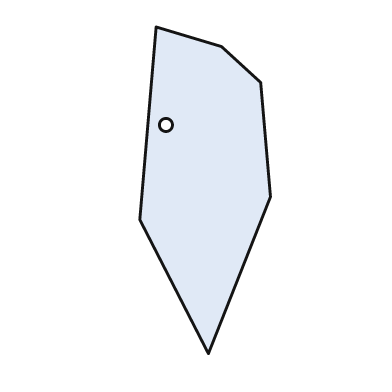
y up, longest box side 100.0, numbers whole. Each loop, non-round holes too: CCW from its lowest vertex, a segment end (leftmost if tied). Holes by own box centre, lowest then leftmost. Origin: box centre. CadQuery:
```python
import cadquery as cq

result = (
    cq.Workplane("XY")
    .moveTo(1.0, -50.0)
    .lineTo(20.0, -2.0)
    .lineTo(17.0, 33.0)
    .lineTo(5.0, 44.0)
    .lineTo(-15.0, 50.0)
    .lineTo(-20.0, -9.0)
    .close()
    .moveTo(-12.0, 20.0)
    .circle(2.0)
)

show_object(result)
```